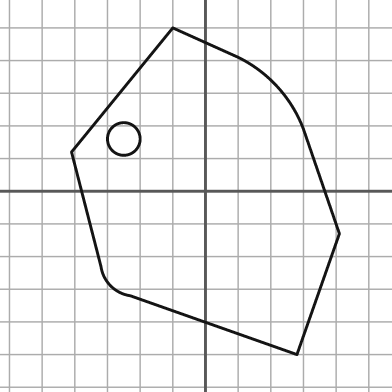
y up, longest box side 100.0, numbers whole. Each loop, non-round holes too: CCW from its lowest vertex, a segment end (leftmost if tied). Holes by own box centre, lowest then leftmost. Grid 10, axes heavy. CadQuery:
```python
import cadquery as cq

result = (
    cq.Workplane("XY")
    .moveTo(28.0, -50.0)
    .lineTo(41.0, -13.0)
    .lineTo(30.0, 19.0)
    .threePointArc((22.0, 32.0), (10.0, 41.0))
    .lineTo(-10.0, 50.0)
    .lineTo(-41.0, 12.0)
    .lineTo(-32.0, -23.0)
    .threePointArc((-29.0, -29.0), (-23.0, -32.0))
    .close()
    .moveTo(-25.0, 16.0)
    .circle(5.0)
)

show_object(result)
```